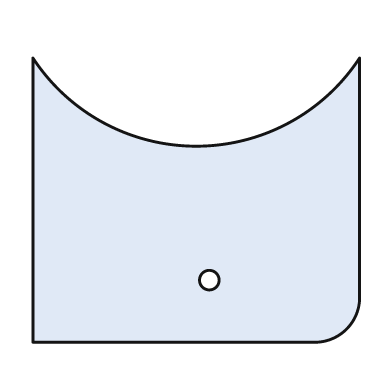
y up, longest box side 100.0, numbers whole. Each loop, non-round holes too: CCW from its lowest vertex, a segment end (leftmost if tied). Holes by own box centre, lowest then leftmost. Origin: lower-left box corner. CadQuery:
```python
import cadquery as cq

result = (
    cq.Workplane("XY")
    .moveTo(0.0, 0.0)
    .lineTo(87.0, 0.0)
    .threePointArc((96.0, 4.0), (100.0, 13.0))
    .lineTo(100.0, 87.0)
    .threePointArc((50.0, 60.0), (0.0, 87.0))
    .close()
    .moveTo(54.0, 19.0)
    .circle(3.0)
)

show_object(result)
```